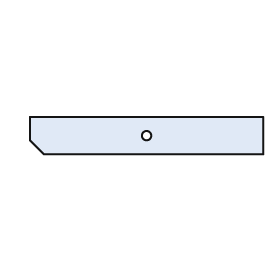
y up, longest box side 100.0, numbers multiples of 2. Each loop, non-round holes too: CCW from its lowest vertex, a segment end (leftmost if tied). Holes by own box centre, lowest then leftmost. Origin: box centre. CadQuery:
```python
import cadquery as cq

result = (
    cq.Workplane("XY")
    .moveTo(-44.0, -8.0)
    .lineTo(50.0, -8.0)
    .lineTo(50.0, 8.0)
    .lineTo(-50.0, 8.0)
    .lineTo(-50.0, -2.0)
    .close()
    .moveTo(0.0, 0.0)
    .circle(2.0)
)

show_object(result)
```